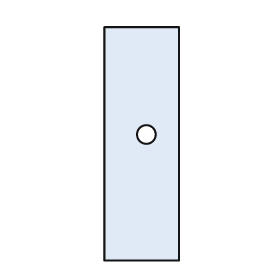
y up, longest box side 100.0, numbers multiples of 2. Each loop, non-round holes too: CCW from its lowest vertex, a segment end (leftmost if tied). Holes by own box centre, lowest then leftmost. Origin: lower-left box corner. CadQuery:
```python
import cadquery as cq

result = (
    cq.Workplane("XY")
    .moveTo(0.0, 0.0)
    .lineTo(32.0, 0.0)
    .lineTo(32.0, 100.0)
    .lineTo(0.0, 100.0)
    .close()
    .moveTo(18.0, 54.0)
    .circle(4.0)
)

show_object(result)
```